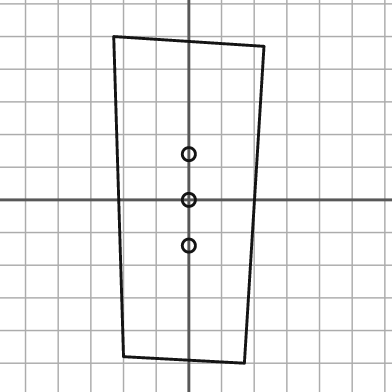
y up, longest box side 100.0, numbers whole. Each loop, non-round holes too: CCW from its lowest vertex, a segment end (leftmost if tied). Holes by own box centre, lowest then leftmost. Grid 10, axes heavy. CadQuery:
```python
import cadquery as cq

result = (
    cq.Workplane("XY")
    .moveTo(17.0, -50.0)
    .lineTo(23.0, 47.0)
    .lineTo(-23.0, 50.0)
    .lineTo(-20.0, -48.0)
    .close()
    .moveTo(0.0, -14.0)
    .circle(2.0)
    .moveTo(0.0, 0.0)
    .circle(2.0)
    .moveTo(0.0, 14.0)
    .circle(2.0)
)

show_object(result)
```